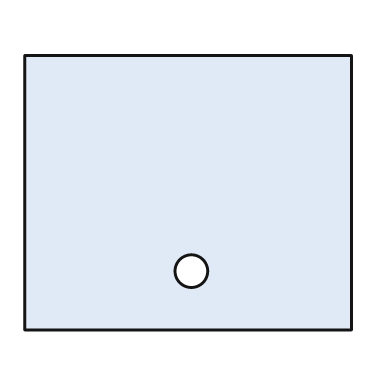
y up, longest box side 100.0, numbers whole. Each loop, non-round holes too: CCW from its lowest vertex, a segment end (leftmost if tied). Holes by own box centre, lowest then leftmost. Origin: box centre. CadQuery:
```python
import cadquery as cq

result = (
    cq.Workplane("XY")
    .moveTo(-50.0, -42.0)
    .lineTo(50.0, -42.0)
    .lineTo(50.0, 42.0)
    .lineTo(-50.0, 42.0)
    .close()
    .moveTo(1.0, -24.0)
    .circle(5.0)
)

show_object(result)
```